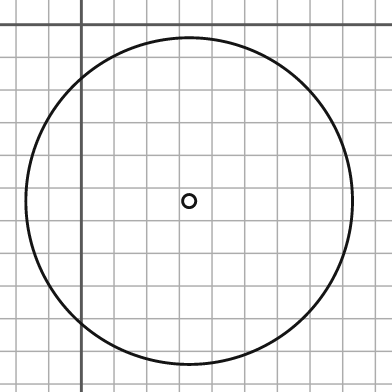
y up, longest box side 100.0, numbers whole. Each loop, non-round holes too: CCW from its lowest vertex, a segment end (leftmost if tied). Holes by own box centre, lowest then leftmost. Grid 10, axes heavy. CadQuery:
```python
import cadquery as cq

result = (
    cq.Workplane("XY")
    .moveTo(33.0, -54.0)
    .circle(50.0)
    .moveTo(33.0, -54.0)
    .circle(2.0)
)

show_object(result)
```